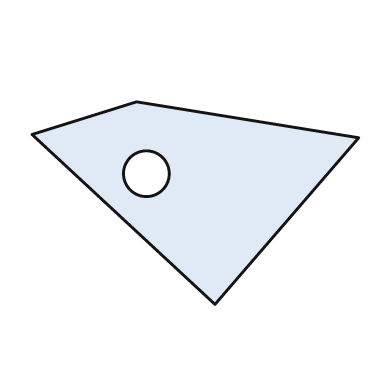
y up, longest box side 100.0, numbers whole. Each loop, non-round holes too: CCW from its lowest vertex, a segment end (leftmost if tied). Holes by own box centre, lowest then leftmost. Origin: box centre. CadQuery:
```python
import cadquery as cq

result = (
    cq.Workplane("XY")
    .moveTo(6.0, -31.0)
    .lineTo(50.0, 20.0)
    .lineTo(-18.0, 31.0)
    .lineTo(-50.0, 21.0)
    .close()
    .moveTo(-15.0, 9.0)
    .circle(7.0)
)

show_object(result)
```